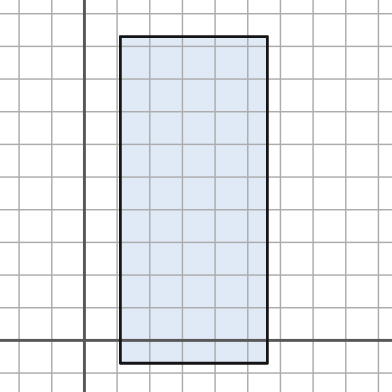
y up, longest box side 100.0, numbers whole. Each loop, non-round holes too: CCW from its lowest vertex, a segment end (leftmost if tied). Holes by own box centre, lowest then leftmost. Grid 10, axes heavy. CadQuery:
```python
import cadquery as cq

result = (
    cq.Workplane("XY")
    .moveTo(11.0, -7.0)
    .lineTo(56.0, -7.0)
    .lineTo(56.0, 93.0)
    .lineTo(11.0, 93.0)
    .close()
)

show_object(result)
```